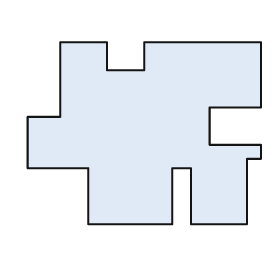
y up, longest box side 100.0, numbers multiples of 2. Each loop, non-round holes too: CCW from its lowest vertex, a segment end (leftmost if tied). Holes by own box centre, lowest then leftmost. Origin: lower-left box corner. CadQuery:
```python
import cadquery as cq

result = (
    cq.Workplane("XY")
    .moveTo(26.0, 0.0)
    .lineTo(62.0, 0.0)
    .lineTo(62.0, 24.0)
    .lineTo(70.0, 24.0)
    .lineTo(70.0, 0.0)
    .lineTo(94.0, 0.0)
    .lineTo(94.0, 28.0)
    .lineTo(100.0, 28.0)
    .lineTo(100.0, 34.0)
    .lineTo(78.0, 34.0)
    .lineTo(78.0, 50.0)
    .lineTo(100.0, 50.0)
    .lineTo(100.0, 78.0)
    .lineTo(50.0, 78.0)
    .lineTo(50.0, 66.0)
    .lineTo(34.0, 66.0)
    .lineTo(34.0, 78.0)
    .lineTo(14.0, 78.0)
    .lineTo(14.0, 46.0)
    .lineTo(0.0, 46.0)
    .lineTo(0.0, 24.0)
    .lineTo(26.0, 24.0)
    .close()
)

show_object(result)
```